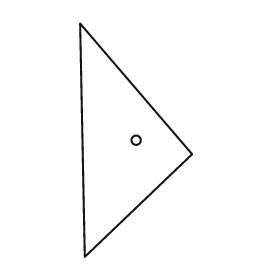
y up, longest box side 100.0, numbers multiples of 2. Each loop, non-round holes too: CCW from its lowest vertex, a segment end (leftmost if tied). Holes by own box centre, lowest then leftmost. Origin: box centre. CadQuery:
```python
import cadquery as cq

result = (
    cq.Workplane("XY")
    .moveTo(-22.0, -50.0)
    .lineTo(24.0, -6.0)
    .lineTo(-24.0, 50.0)
    .close()
    .moveTo(0.0, 0.0)
    .circle(2.0)
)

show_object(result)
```